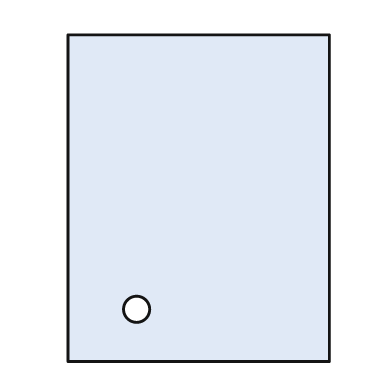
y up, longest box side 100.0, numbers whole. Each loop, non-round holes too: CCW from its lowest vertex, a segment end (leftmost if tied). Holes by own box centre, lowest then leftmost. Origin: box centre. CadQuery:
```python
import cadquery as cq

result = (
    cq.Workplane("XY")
    .moveTo(-40.0, -50.0)
    .lineTo(40.0, -50.0)
    .lineTo(40.0, 50.0)
    .lineTo(-40.0, 50.0)
    .close()
    .moveTo(-19.0, -34.0)
    .circle(4.0)
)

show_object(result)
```